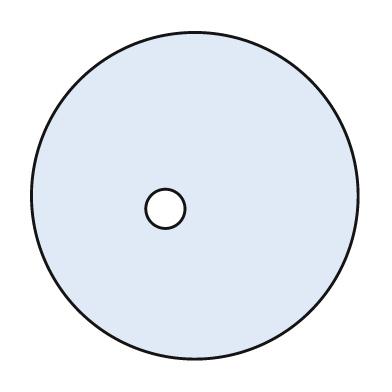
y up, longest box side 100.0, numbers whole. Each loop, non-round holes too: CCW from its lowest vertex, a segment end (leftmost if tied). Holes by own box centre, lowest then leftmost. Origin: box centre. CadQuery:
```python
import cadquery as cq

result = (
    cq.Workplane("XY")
    .moveTo(0.0, 0.0)
    .circle(50.0)
    .moveTo(-9.0, -4.0)
    .circle(6.0)
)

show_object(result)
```